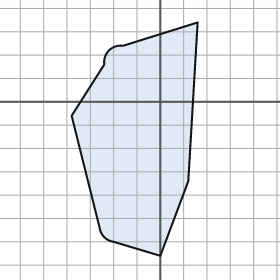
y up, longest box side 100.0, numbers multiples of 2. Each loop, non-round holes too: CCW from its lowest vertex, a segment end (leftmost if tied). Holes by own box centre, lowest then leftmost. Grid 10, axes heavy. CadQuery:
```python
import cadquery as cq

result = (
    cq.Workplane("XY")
    .moveTo(0.0, -66.0)
    .lineTo(12.0, -34.0)
    .lineTo(16.0, 34.0)
    .lineTo(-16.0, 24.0)
    .threePointArc((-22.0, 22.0), (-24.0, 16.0))
    .lineTo(-38.0, -6.0)
    .lineTo(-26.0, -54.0)
    .threePointArc((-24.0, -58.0), (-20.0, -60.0))
    .close()
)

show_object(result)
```